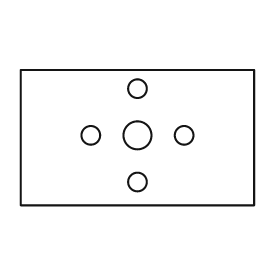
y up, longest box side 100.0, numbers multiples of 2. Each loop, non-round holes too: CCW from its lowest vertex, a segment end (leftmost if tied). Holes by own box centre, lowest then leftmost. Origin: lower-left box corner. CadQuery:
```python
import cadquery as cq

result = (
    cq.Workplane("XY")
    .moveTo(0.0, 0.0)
    .lineTo(100.0, 0.0)
    .lineTo(100.0, 58.0)
    .lineTo(0.0, 58.0)
    .close()
    .moveTo(50.0, 10.0)
    .circle(4.0)
    .moveTo(30.0, 30.0)
    .circle(4.0)
    .moveTo(50.0, 30.0)
    .circle(6.0)
    .moveTo(70.0, 30.0)
    .circle(4.0)
    .moveTo(50.0, 50.0)
    .circle(4.0)
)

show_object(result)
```